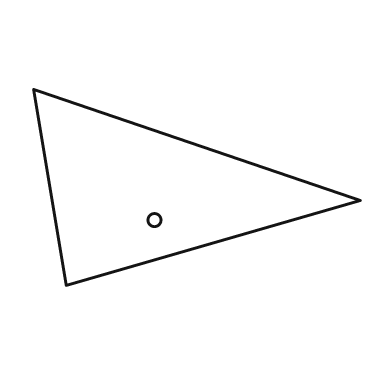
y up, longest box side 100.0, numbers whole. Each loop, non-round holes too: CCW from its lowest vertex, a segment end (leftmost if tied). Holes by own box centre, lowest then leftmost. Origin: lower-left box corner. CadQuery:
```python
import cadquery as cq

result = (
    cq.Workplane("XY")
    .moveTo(10.0, 0.0)
    .lineTo(100.0, 26.0)
    .lineTo(0.0, 60.0)
    .close()
    .moveTo(37.0, 20.0)
    .circle(2.0)
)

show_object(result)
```